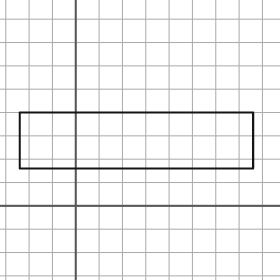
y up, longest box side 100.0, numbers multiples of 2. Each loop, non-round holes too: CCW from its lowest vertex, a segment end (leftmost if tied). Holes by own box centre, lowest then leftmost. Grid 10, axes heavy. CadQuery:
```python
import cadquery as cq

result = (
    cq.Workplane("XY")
    .moveTo(-24.0, 16.0)
    .lineTo(76.0, 16.0)
    .lineTo(76.0, 40.0)
    .lineTo(-24.0, 40.0)
    .close()
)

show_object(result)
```